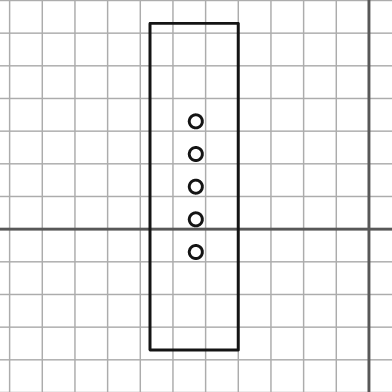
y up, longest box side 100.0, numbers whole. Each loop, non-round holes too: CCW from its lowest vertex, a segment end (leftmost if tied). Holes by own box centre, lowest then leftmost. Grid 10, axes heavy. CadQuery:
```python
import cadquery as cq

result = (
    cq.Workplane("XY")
    .moveTo(-67.0, -37.0)
    .lineTo(-40.0, -37.0)
    .lineTo(-40.0, 63.0)
    .lineTo(-67.0, 63.0)
    .close()
    .moveTo(-53.0, -7.0)
    .circle(2.0)
    .moveTo(-53.0, 3.0)
    .circle(2.0)
    .moveTo(-53.0, 13.0)
    .circle(2.0)
    .moveTo(-53.0, 23.0)
    .circle(2.0)
    .moveTo(-53.0, 33.0)
    .circle(2.0)
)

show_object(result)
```